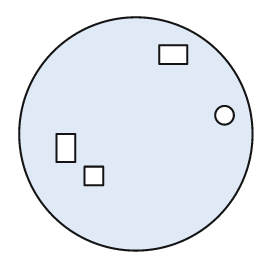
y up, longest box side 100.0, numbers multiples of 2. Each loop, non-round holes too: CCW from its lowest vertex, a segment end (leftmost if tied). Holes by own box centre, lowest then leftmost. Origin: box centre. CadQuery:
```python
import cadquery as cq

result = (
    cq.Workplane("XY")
    .moveTo(0.0, 0.0)
    .circle(50.0)
    .moveTo(-22.0, -22.0)
    .lineTo(-14.0, -22.0)
    .lineTo(-14.0, -14.0)
    .lineTo(-22.0, -14.0)
    .close()
    .moveTo(-34.0, -12.0)
    .lineTo(-26.0, -12.0)
    .lineTo(-26.0, 0.0)
    .lineTo(-34.0, 0.0)
    .close()
    .moveTo(38.0, 8.0)
    .circle(4.0)
    .moveTo(10.0, 30.0)
    .lineTo(22.0, 30.0)
    .lineTo(22.0, 38.0)
    .lineTo(10.0, 38.0)
    .close()
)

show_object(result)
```